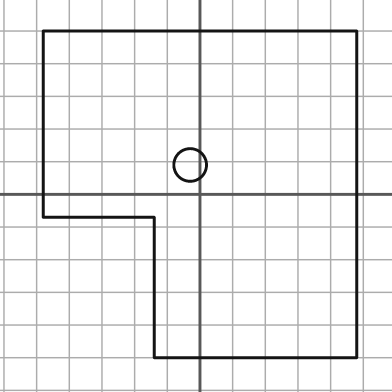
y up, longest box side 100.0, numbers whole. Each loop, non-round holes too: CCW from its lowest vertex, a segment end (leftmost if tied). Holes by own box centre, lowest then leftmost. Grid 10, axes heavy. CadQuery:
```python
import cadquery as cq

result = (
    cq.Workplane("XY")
    .moveTo(-14.0, -50.0)
    .lineTo(48.0, -50.0)
    .lineTo(48.0, 50.0)
    .lineTo(-48.0, 50.0)
    .lineTo(-48.0, -7.0)
    .lineTo(-14.0, -7.0)
    .close()
    .moveTo(-3.0, 9.0)
    .circle(5.0)
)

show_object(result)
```